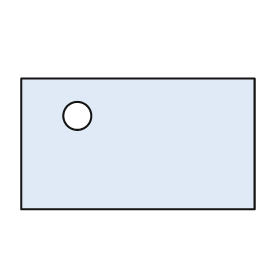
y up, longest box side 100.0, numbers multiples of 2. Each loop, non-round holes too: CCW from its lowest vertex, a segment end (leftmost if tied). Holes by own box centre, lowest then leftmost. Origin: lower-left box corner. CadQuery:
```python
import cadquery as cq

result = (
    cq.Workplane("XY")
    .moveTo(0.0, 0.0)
    .lineTo(100.0, 0.0)
    .lineTo(100.0, 56.0)
    .lineTo(0.0, 56.0)
    .close()
    .moveTo(24.0, 40.0)
    .circle(6.0)
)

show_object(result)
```